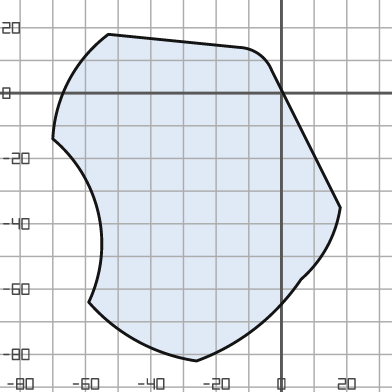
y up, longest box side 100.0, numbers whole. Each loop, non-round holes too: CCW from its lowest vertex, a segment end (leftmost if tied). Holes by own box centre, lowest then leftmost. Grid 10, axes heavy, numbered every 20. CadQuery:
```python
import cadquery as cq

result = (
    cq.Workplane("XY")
    .moveTo(-26.0, -82.0)
    .threePointArc((-8.0, -72.0), (6.0, -57.0))
    .threePointArc((14.0, -47.0), (18.0, -35.0))
    .lineTo(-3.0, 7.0)
    .threePointArc((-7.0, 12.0), (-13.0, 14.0))
    .lineTo(-53.0, 18.0)
    .threePointArc((-65.0, 4.0), (-70.0, -14.0))
    .threePointArc((-56.0, -37.0), (-59.0, -64.0))
    .threePointArc((-44.0, -76.0), (-26.0, -82.0))
    .close()
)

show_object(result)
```